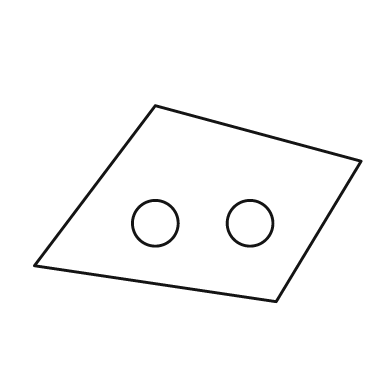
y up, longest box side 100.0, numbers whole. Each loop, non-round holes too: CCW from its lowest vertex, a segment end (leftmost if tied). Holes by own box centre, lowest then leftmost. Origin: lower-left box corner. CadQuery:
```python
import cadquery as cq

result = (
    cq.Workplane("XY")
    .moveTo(74.0, 0.0)
    .lineTo(100.0, 43.0)
    .lineTo(37.0, 60.0)
    .lineTo(0.0, 11.0)
    .close()
    .moveTo(37.0, 24.0)
    .circle(7.0)
    .moveTo(66.0, 24.0)
    .circle(7.0)
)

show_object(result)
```